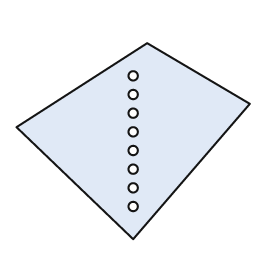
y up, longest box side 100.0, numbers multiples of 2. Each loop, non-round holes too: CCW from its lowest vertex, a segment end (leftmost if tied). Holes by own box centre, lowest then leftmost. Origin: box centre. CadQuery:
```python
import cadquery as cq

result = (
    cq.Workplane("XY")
    .moveTo(0.0, -42.0)
    .lineTo(50.0, 16.0)
    .lineTo(6.0, 42.0)
    .lineTo(-50.0, 6.0)
    .close()
    .moveTo(0.0, -28.0)
    .circle(2.0)
    .moveTo(0.0, -20.0)
    .circle(2.0)
    .moveTo(0.0, -12.0)
    .circle(2.0)
    .moveTo(0.0, -4.0)
    .circle(2.0)
    .moveTo(0.0, 4.0)
    .circle(2.0)
    .moveTo(0.0, 12.0)
    .circle(2.0)
    .moveTo(0.0, 20.0)
    .circle(2.0)
    .moveTo(0.0, 28.0)
    .circle(2.0)
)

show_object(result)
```